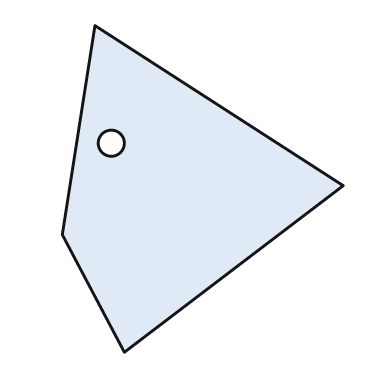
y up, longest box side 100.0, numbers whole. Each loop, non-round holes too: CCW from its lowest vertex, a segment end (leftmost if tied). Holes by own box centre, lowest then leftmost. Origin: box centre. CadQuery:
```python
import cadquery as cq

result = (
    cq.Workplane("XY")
    .moveTo(-24.0, -50.0)
    .lineTo(43.0, 1.0)
    .lineTo(-33.0, 50.0)
    .lineTo(-43.0, -14.0)
    .close()
    .moveTo(-28.0, 14.0)
    .circle(4.0)
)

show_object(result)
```